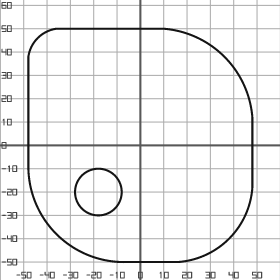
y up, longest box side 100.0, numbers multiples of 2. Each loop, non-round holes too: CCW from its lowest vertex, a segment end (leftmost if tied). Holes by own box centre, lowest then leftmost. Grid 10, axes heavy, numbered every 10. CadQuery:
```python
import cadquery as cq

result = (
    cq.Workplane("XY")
    .moveTo(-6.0, -50.0)
    .lineTo(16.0, -50.0)
    .threePointArc((38.0, -40.0), (48.0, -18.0))
    .lineTo(48.0, 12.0)
    .threePointArc((36.0, 38.0), (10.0, 50.0))
    .lineTo(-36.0, 50.0)
    .threePointArc((-44.0, 46.0), (-48.0, 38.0))
    .lineTo(-48.0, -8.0)
    .threePointArc((-36.0, -38.0), (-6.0, -50.0))
    .close()
    .moveTo(-18.0, -20.0)
    .circle(10.0)
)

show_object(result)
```